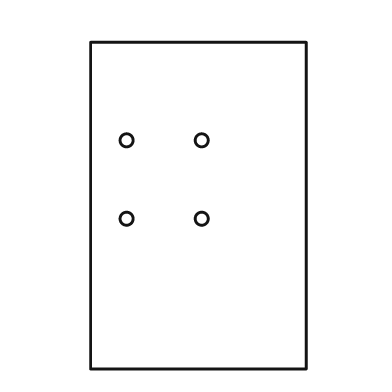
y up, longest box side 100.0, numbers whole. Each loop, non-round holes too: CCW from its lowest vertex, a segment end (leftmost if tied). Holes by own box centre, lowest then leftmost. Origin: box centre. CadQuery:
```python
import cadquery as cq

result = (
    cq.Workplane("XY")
    .moveTo(-33.0, -50.0)
    .lineTo(33.0, -50.0)
    .lineTo(33.0, 50.0)
    .lineTo(-33.0, 50.0)
    .close()
    .moveTo(-22.0, -4.0)
    .circle(2.0)
    .moveTo(1.0, -4.0)
    .circle(2.0)
    .moveTo(-22.0, 20.0)
    .circle(2.0)
    .moveTo(1.0, 20.0)
    .circle(2.0)
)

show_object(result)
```